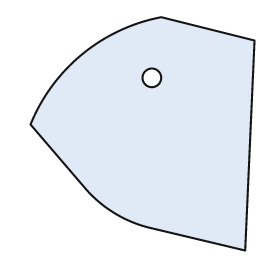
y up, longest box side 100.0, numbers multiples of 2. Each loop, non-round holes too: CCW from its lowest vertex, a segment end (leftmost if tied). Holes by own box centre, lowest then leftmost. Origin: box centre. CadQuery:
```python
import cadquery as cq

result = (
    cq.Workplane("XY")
    .moveTo(44.0, -50.0)
    .lineTo(48.0, 40.0)
    .lineTo(8.0, 50.0)
    .threePointArc((-26.0, 34.0), (-48.0, 4.0))
    .lineTo(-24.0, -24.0)
    .threePointArc((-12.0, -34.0), (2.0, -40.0))
    .close()
    .moveTo(4.0, 24.0)
    .circle(4.0)
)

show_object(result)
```